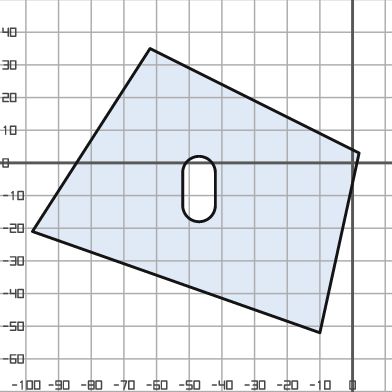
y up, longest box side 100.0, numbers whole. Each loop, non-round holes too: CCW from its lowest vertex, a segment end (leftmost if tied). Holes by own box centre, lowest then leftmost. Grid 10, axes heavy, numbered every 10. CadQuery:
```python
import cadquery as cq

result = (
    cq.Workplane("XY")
    .moveTo(-10.0, -52.0)
    .lineTo(2.0, 3.0)
    .lineTo(-62.0, 35.0)
    .lineTo(-98.0, -21.0)
    .close()
    .moveTo(-52.0, -13.0)
    .threePointArc((-47.0, -18.0), (-42.0, -13.0))
    .lineTo(-42.0, -3.0)
    .threePointArc((-47.0, 2.0), (-52.0, -3.0))
    .close()
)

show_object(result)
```